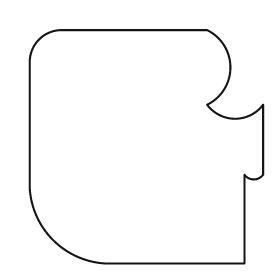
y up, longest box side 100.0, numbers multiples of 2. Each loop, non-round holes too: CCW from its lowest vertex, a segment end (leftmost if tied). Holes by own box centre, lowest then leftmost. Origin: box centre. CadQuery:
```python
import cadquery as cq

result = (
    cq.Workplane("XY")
    .moveTo(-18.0, -50.0)
    .lineTo(42.0, -50.0)
    .lineTo(42.0, -12.0)
    .threePointArc((46.0, -14.0), (50.0, -12.0))
    .lineTo(50.0, 18.0)
    .threePointArc((38.0, 12.0), (26.0, 18.0))
    .threePointArc((36.0, 34.0), (26.0, 50.0))
    .lineTo(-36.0, 50.0)
    .threePointArc((-46.0, 46.0), (-50.0, 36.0))
    .lineTo(-50.0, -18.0)
    .threePointArc((-40.0, -40.0), (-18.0, -50.0))
    .close()
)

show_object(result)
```